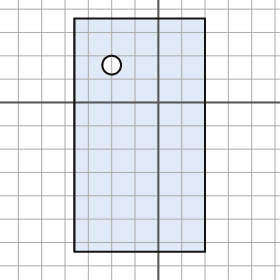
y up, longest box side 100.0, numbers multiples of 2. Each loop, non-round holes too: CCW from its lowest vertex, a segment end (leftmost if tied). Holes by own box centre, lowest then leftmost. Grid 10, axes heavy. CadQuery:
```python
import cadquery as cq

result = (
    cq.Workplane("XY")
    .moveTo(-36.0, -64.0)
    .lineTo(20.0, -64.0)
    .lineTo(20.0, 36.0)
    .lineTo(-36.0, 36.0)
    .close()
    .moveTo(-20.0, 16.0)
    .circle(4.0)
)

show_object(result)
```